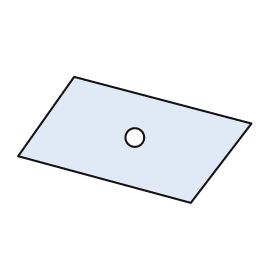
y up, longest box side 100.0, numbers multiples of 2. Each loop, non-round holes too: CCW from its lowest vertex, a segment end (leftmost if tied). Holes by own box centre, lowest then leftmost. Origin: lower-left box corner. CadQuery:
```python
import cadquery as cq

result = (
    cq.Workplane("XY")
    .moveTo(74.0, 0.0)
    .lineTo(100.0, 34.0)
    .lineTo(24.0, 54.0)
    .lineTo(0.0, 20.0)
    .close()
    .moveTo(50.0, 28.0)
    .circle(4.0)
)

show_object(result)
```